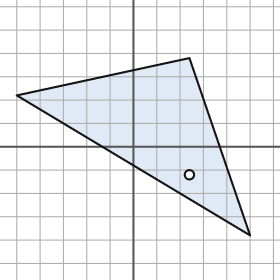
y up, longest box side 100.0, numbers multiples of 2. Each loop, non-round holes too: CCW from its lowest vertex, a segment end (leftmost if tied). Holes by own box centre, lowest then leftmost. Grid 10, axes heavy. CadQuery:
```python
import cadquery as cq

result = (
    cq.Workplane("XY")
    .moveTo(50.0, -38.0)
    .lineTo(24.0, 38.0)
    .lineTo(-50.0, 22.0)
    .close()
    .moveTo(24.0, -12.0)
    .circle(2.0)
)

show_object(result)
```